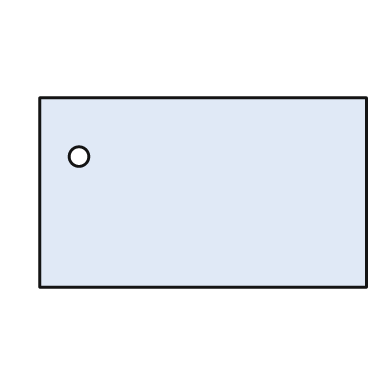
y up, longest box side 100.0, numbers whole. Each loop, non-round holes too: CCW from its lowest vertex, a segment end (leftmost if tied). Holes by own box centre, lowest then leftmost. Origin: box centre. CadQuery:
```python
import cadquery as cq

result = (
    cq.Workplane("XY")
    .moveTo(-50.0, -29.0)
    .lineTo(50.0, -29.0)
    .lineTo(50.0, 29.0)
    .lineTo(-50.0, 29.0)
    .close()
    .moveTo(-38.0, 11.0)
    .circle(3.0)
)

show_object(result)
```